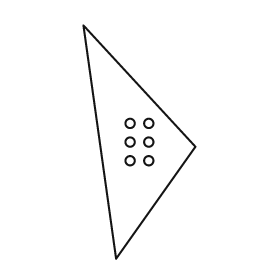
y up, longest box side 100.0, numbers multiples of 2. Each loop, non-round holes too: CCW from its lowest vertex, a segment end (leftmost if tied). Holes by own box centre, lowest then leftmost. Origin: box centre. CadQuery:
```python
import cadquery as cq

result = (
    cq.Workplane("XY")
    .moveTo(-10.0, -50.0)
    .lineTo(24.0, -2.0)
    .lineTo(-24.0, 50.0)
    .close()
    .moveTo(-4.0, -8.0)
    .circle(2.0)
    .moveTo(4.0, -8.0)
    .circle(2.0)
    .moveTo(-4.0, 0.0)
    .circle(2.0)
    .moveTo(4.0, 0.0)
    .circle(2.0)
    .moveTo(-4.0, 8.0)
    .circle(2.0)
    .moveTo(4.0, 8.0)
    .circle(2.0)
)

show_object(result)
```